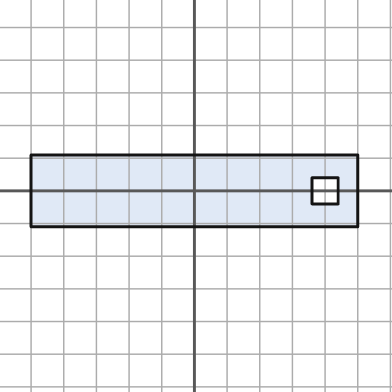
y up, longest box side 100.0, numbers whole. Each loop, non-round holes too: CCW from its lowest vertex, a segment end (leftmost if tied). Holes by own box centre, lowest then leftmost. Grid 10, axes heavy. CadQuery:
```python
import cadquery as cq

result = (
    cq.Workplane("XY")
    .moveTo(-50.0, -11.0)
    .lineTo(50.0, -11.0)
    .lineTo(50.0, 11.0)
    .lineTo(-50.0, 11.0)
    .close()
    .moveTo(36.0, -4.0)
    .lineTo(44.0, -4.0)
    .lineTo(44.0, 4.0)
    .lineTo(36.0, 4.0)
    .close()
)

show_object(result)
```